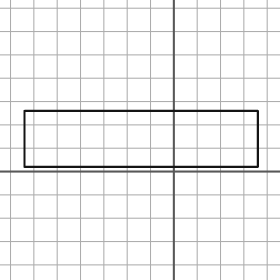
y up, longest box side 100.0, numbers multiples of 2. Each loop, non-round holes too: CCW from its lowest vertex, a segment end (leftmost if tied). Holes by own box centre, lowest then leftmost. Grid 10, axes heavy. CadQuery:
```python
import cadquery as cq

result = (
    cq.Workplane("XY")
    .moveTo(-64.0, 2.0)
    .lineTo(36.0, 2.0)
    .lineTo(36.0, 26.0)
    .lineTo(-64.0, 26.0)
    .close()
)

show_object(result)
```